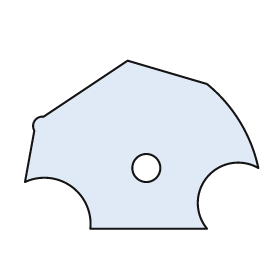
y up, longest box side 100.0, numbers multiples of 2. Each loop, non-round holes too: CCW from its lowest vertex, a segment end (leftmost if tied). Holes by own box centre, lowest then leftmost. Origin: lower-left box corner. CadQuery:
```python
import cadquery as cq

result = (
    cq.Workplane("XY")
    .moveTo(28.0, 0.0)
    .lineTo(78.0, 0.0)
    .threePointArc((78.0, 22.0), (100.0, 26.0))
    .threePointArc((92.0, 46.0), (78.0, 62.0))
    .lineTo(44.0, 72.0)
    .lineTo(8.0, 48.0)
    .threePointArc((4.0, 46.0), (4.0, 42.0))
    .lineTo(0.0, 20.0)
    .threePointArc((20.0, 18.0), (28.0, 0.0))
    .close()
    .moveTo(52.0, 26.0)
    .circle(6.0)
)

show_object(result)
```